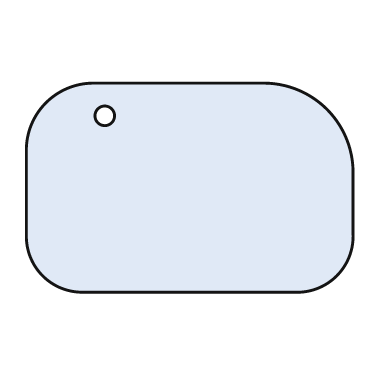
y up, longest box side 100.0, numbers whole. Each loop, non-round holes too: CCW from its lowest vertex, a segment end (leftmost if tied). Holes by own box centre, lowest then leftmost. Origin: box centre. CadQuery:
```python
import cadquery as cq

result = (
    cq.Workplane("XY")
    .moveTo(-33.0, -32.0)
    .lineTo(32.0, -32.0)
    .threePointArc((45.0, -27.0), (50.0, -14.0))
    .lineTo(50.0, 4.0)
    .threePointArc((42.0, 24.0), (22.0, 32.0))
    .lineTo(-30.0, 32.0)
    .threePointArc((-44.0, 26.0), (-50.0, 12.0))
    .lineTo(-50.0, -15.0)
    .threePointArc((-45.0, -27.0), (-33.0, -32.0))
    .close()
    .moveTo(-26.0, 22.0)
    .circle(3.0)
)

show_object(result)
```